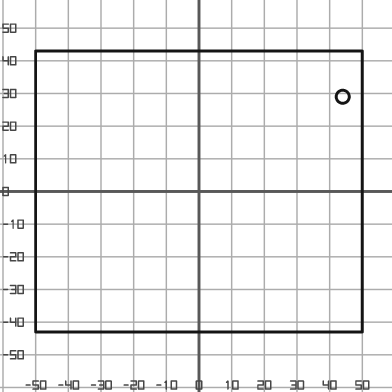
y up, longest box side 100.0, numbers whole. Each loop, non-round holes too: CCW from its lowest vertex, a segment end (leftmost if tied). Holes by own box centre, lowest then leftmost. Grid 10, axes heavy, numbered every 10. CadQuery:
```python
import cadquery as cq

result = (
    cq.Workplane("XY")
    .moveTo(-50.0, -43.0)
    .lineTo(50.0, -43.0)
    .lineTo(50.0, 43.0)
    .lineTo(-50.0, 43.0)
    .close()
    .moveTo(44.0, 29.0)
    .circle(2.0)
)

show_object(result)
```